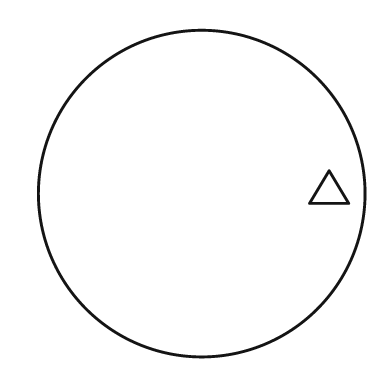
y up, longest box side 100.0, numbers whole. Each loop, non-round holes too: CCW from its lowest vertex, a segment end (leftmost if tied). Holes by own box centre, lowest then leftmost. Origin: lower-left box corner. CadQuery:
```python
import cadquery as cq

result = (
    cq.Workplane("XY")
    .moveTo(50.0, 50.0)
    .circle(50.0)
    .moveTo(83.0, 47.0)
    .lineTo(95.0, 47.0)
    .lineTo(89.0, 57.0)
    .close()
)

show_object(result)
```